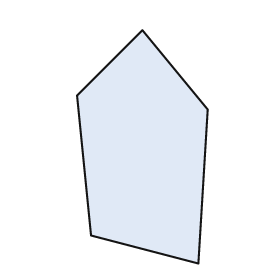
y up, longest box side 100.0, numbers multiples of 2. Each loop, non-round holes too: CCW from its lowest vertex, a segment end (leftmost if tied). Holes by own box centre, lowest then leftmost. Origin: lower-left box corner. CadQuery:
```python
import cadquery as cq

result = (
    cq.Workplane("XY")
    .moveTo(52.0, 0.0)
    .lineTo(56.0, 66.0)
    .lineTo(28.0, 100.0)
    .lineTo(0.0, 72.0)
    .lineTo(6.0, 12.0)
    .close()
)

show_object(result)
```